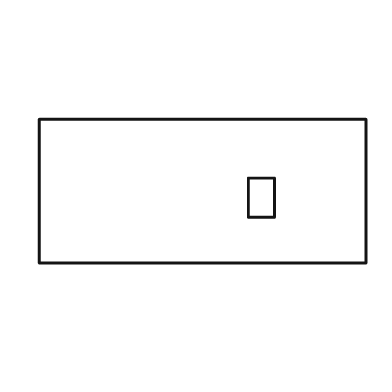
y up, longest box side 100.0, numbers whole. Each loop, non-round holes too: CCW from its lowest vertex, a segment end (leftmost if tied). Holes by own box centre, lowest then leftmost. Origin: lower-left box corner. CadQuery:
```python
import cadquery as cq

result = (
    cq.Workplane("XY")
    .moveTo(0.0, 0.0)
    .lineTo(100.0, 0.0)
    .lineTo(100.0, 44.0)
    .lineTo(0.0, 44.0)
    .close()
    .moveTo(64.0, 14.0)
    .lineTo(72.0, 14.0)
    .lineTo(72.0, 26.0)
    .lineTo(64.0, 26.0)
    .close()
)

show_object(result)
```